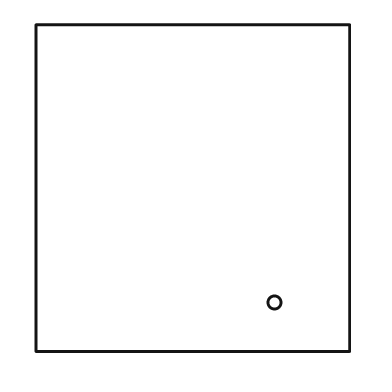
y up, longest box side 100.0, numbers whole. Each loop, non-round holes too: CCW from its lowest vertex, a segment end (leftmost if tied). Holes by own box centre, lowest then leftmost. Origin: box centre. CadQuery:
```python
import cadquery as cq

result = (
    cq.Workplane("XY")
    .moveTo(-48.0, -50.0)
    .lineTo(48.0, -50.0)
    .lineTo(48.0, 50.0)
    .lineTo(-48.0, 50.0)
    .close()
    .moveTo(25.0, -35.0)
    .circle(2.0)
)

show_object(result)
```